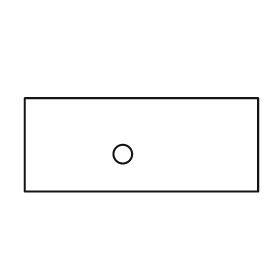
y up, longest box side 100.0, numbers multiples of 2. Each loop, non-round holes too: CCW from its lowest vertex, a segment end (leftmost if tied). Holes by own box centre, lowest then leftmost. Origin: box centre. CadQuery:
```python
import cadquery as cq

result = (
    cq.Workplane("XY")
    .moveTo(-50.0, -20.0)
    .lineTo(50.0, -20.0)
    .lineTo(50.0, 20.0)
    .lineTo(-50.0, 20.0)
    .close()
    .moveTo(-8.0, -4.0)
    .circle(4.0)
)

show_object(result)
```